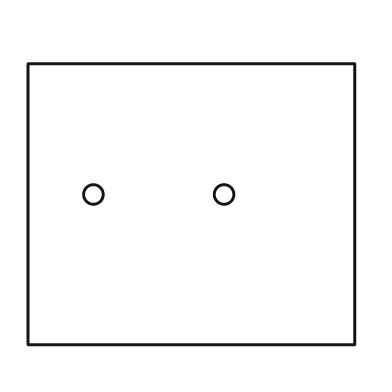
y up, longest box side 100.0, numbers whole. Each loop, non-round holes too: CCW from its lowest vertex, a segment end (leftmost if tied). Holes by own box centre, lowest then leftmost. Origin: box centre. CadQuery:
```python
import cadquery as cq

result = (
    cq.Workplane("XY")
    .moveTo(-50.0, -43.0)
    .lineTo(50.0, -43.0)
    .lineTo(50.0, 43.0)
    .lineTo(-50.0, 43.0)
    .close()
    .moveTo(-30.0, 3.0)
    .circle(3.0)
    .moveTo(10.0, 3.0)
    .circle(3.0)
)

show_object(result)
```